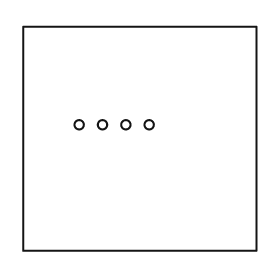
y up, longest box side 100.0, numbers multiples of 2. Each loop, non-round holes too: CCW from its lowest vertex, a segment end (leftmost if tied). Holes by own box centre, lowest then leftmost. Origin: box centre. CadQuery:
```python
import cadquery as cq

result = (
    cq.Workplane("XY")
    .moveTo(-50.0, -48.0)
    .lineTo(50.0, -48.0)
    .lineTo(50.0, 48.0)
    .lineTo(-50.0, 48.0)
    .close()
    .moveTo(-26.0, 6.0)
    .circle(2.0)
    .moveTo(-16.0, 6.0)
    .circle(2.0)
    .moveTo(-6.0, 6.0)
    .circle(2.0)
    .moveTo(4.0, 6.0)
    .circle(2.0)
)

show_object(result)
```